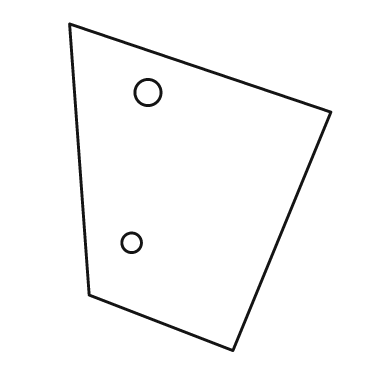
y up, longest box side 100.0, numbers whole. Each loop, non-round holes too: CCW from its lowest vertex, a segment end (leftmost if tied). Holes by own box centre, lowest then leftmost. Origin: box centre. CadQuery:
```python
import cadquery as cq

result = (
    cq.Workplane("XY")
    .moveTo(10.0, -50.0)
    .lineTo(40.0, 23.0)
    .lineTo(-40.0, 50.0)
    .lineTo(-34.0, -33.0)
    .close()
    .moveTo(-21.0, -17.0)
    .circle(3.0)
    .moveTo(-16.0, 29.0)
    .circle(4.0)
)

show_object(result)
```